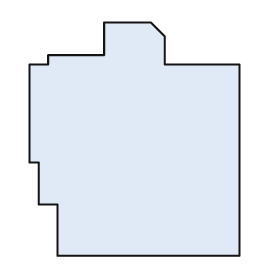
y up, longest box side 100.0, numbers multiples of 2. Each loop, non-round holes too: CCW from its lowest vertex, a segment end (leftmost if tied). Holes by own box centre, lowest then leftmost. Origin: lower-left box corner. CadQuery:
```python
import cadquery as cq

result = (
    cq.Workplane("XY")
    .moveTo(12.0, 0.0)
    .lineTo(90.0, 0.0)
    .lineTo(90.0, 82.0)
    .lineTo(58.0, 82.0)
    .lineTo(58.0, 94.0)
    .lineTo(52.0, 100.0)
    .lineTo(32.0, 100.0)
    .lineTo(32.0, 86.0)
    .lineTo(8.0, 86.0)
    .lineTo(8.0, 82.0)
    .lineTo(0.0, 82.0)
    .lineTo(0.0, 40.0)
    .lineTo(4.0, 40.0)
    .lineTo(4.0, 22.0)
    .lineTo(12.0, 22.0)
    .close()
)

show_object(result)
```